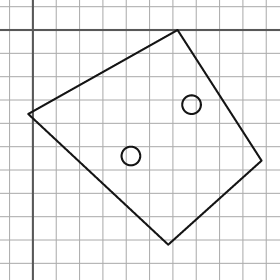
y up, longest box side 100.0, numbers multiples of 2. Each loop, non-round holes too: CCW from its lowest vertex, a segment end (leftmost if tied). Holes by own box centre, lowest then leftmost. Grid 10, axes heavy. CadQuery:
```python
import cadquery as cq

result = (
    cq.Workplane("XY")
    .moveTo(58.0, -92.0)
    .lineTo(98.0, -56.0)
    .lineTo(62.0, 0.0)
    .lineTo(-2.0, -36.0)
    .close()
    .moveTo(42.0, -54.0)
    .circle(4.0)
    .moveTo(68.0, -32.0)
    .circle(4.0)
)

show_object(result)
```